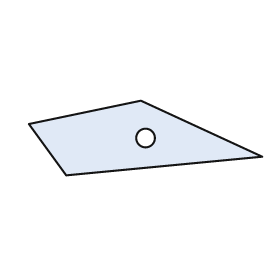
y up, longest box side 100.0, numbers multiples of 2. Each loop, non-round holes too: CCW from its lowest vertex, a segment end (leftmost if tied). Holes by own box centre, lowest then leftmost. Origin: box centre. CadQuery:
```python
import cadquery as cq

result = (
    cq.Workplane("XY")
    .moveTo(-34.0, -16.0)
    .lineTo(50.0, -8.0)
    .lineTo(-2.0, 16.0)
    .lineTo(-50.0, 6.0)
    .close()
    .moveTo(0.0, 0.0)
    .circle(4.0)
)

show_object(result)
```